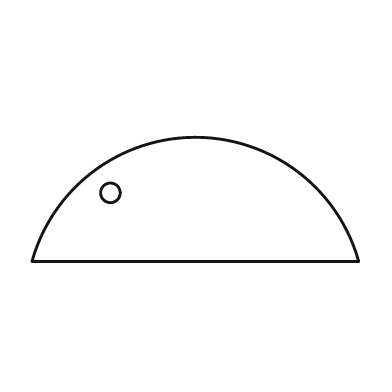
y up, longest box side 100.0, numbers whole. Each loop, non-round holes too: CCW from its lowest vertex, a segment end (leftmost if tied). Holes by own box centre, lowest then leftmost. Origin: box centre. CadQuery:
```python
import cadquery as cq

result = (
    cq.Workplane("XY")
    .moveTo(-50.0, -19.0)
    .lineTo(50.0, -19.0)
    .threePointArc((0.0, 19.0), (-50.0, -19.0))
    .close()
    .moveTo(-26.0, 2.0)
    .circle(3.0)
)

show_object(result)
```